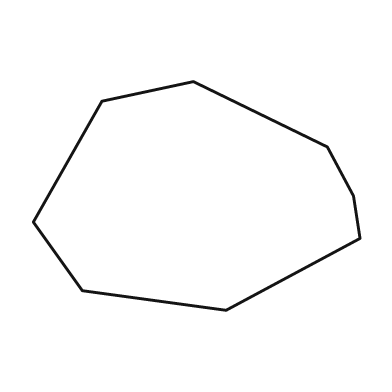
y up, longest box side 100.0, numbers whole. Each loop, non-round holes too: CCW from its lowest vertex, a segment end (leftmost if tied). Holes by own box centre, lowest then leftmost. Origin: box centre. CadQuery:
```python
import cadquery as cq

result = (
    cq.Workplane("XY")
    .moveTo(9.0, -35.0)
    .lineTo(50.0, -13.0)
    .lineTo(48.0, 0.0)
    .lineTo(40.0, 15.0)
    .lineTo(-1.0, 35.0)
    .lineTo(-29.0, 29.0)
    .lineTo(-50.0, -8.0)
    .lineTo(-35.0, -29.0)
    .close()
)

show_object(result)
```